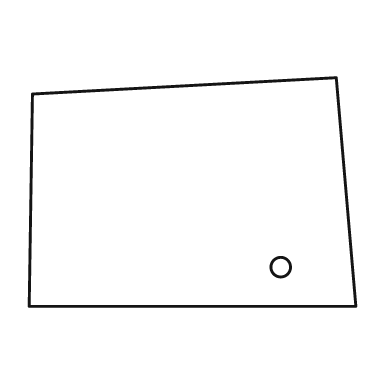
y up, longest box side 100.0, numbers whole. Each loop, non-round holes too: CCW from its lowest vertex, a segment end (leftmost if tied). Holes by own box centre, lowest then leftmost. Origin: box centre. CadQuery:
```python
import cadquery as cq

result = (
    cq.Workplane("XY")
    .moveTo(-50.0, -35.0)
    .lineTo(50.0, -35.0)
    .lineTo(44.0, 35.0)
    .lineTo(-49.0, 30.0)
    .close()
    .moveTo(27.0, -23.0)
    .circle(3.0)
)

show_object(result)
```